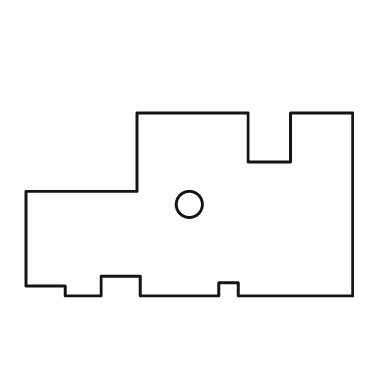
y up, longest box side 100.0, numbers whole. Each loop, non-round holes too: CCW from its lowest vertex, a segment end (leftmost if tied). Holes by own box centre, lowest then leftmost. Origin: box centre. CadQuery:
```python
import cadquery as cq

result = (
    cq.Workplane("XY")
    .moveTo(-38.0, -28.0)
    .lineTo(-27.0, -28.0)
    .lineTo(-27.0, -22.0)
    .lineTo(-15.0, -22.0)
    .lineTo(-15.0, -28.0)
    .lineTo(9.0, -28.0)
    .lineTo(9.0, -24.0)
    .lineTo(15.0, -24.0)
    .lineTo(15.0, -28.0)
    .lineTo(50.0, -28.0)
    .lineTo(50.0, 28.0)
    .lineTo(31.0, 28.0)
    .lineTo(31.0, 13.0)
    .lineTo(18.0, 13.0)
    .lineTo(18.0, 28.0)
    .lineTo(-16.0, 28.0)
    .lineTo(-16.0, 4.0)
    .lineTo(-50.0, 4.0)
    .lineTo(-50.0, -25.0)
    .lineTo(-38.0, -25.0)
    .close()
    .moveTo(0.0, 0.0)
    .circle(4.0)
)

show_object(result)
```